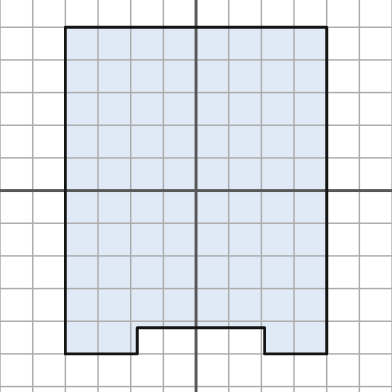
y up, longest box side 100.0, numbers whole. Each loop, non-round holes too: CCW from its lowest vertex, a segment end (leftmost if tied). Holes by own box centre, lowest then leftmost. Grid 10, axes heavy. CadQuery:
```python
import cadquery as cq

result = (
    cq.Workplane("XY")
    .moveTo(-40.0, -50.0)
    .lineTo(-18.0, -50.0)
    .lineTo(-18.0, -42.0)
    .lineTo(21.0, -42.0)
    .lineTo(21.0, -50.0)
    .lineTo(40.0, -50.0)
    .lineTo(40.0, 50.0)
    .lineTo(-40.0, 50.0)
    .close()
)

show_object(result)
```